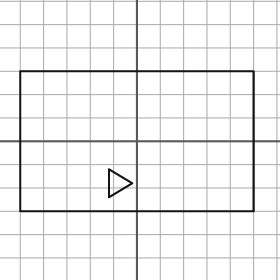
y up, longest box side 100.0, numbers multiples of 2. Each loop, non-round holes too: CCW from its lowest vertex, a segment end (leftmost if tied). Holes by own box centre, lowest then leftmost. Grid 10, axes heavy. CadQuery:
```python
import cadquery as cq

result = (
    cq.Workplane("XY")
    .moveTo(-50.0, -30.0)
    .lineTo(50.0, -30.0)
    .lineTo(50.0, 30.0)
    .lineTo(-50.0, 30.0)
    .close()
    .moveTo(-12.0, -24.0)
    .lineTo(-2.0, -18.0)
    .lineTo(-12.0, -12.0)
    .close()
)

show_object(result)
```